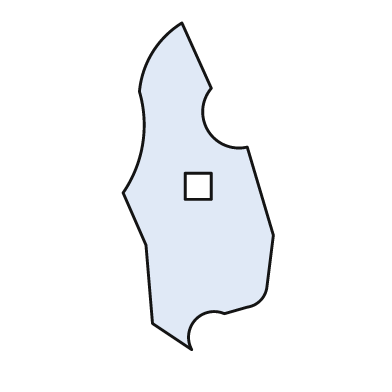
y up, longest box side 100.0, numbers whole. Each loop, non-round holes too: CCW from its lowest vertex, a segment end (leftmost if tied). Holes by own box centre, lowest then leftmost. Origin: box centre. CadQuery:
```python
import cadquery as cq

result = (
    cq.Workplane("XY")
    .moveTo(-2.0, -50.0)
    .threePointArc((-1.0, -41.0), (8.0, -39.0))
    .lineTo(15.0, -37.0)
    .threePointArc((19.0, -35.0), (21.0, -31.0))
    .lineTo(23.0, -15.0)
    .lineTo(15.0, 12.0)
    .threePointArc((3.0, 17.0), (4.0, 30.0))
    .lineTo(-5.0, 50.0)
    .threePointArc((-14.0, 41.0), (-18.0, 29.0))
    .threePointArc((-17.0, 13.0), (-23.0, -2.0))
    .lineTo(-16.0, -18.0)
    .lineTo(-14.0, -42.0)
    .close()
    .moveTo(-4.0, -4.0)
    .lineTo(4.0, -4.0)
    .lineTo(4.0, 4.0)
    .lineTo(-4.0, 4.0)
    .close()
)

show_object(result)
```